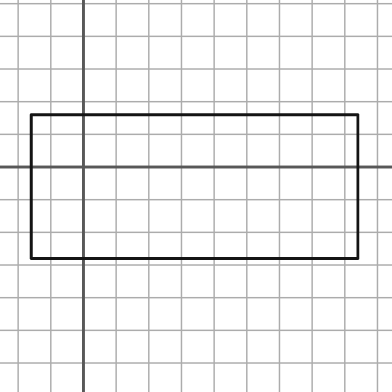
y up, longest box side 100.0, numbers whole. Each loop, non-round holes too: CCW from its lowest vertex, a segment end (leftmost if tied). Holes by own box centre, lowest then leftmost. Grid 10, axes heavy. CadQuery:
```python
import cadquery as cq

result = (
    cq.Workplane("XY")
    .moveTo(-16.0, -28.0)
    .lineTo(84.0, -28.0)
    .lineTo(84.0, 16.0)
    .lineTo(-16.0, 16.0)
    .close()
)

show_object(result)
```